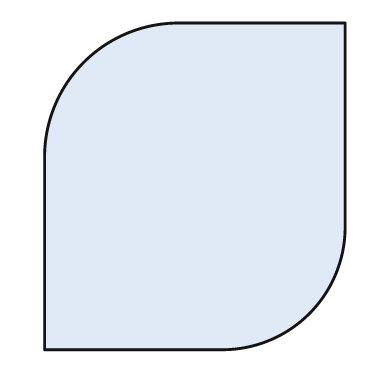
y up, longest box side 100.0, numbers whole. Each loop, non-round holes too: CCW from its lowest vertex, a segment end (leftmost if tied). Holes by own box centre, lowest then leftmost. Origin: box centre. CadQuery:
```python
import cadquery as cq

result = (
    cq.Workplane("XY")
    .moveTo(-46.0, -50.0)
    .lineTo(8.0, -50.0)
    .threePointArc((35.0, -39.0), (46.0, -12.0))
    .lineTo(46.0, 50.0)
    .lineTo(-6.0, 50.0)
    .threePointArc((-34.0, 38.0), (-46.0, 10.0))
    .close()
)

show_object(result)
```